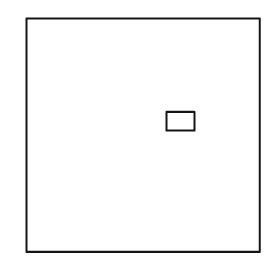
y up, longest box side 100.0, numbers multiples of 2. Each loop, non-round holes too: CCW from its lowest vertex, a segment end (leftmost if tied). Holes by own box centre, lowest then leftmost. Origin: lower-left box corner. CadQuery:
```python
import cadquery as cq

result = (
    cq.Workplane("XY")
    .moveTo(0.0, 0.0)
    .lineTo(100.0, 0.0)
    .lineTo(100.0, 100.0)
    .lineTo(0.0, 100.0)
    .close()
    .moveTo(60.0, 52.0)
    .lineTo(72.0, 52.0)
    .lineTo(72.0, 60.0)
    .lineTo(60.0, 60.0)
    .close()
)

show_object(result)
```